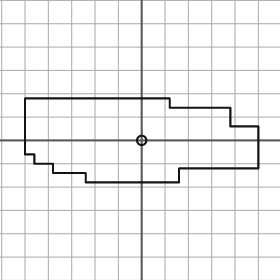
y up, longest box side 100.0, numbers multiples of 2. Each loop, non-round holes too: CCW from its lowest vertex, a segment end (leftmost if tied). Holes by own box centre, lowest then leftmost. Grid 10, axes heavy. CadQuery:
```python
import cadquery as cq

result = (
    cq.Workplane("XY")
    .moveTo(-24.0, -18.0)
    .lineTo(16.0, -18.0)
    .lineTo(16.0, -12.0)
    .lineTo(50.0, -12.0)
    .lineTo(50.0, 6.0)
    .lineTo(38.0, 6.0)
    .lineTo(38.0, 14.0)
    .lineTo(12.0, 14.0)
    .lineTo(12.0, 18.0)
    .lineTo(-50.0, 18.0)
    .lineTo(-50.0, -6.0)
    .lineTo(-46.0, -6.0)
    .lineTo(-46.0, -10.0)
    .lineTo(-38.0, -10.0)
    .lineTo(-38.0, -14.0)
    .lineTo(-24.0, -14.0)
    .close()
    .moveTo(0.0, 0.0)
    .circle(2.0)
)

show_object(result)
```